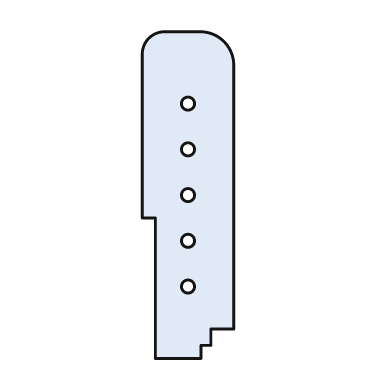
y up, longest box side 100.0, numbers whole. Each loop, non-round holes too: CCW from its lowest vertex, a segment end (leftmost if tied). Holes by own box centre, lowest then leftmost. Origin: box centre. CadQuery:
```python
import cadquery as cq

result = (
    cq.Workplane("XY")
    .moveTo(-10.0, -50.0)
    .lineTo(4.0, -50.0)
    .lineTo(4.0, -46.0)
    .lineTo(7.0, -46.0)
    .lineTo(7.0, -41.0)
    .lineTo(14.0, -41.0)
    .lineTo(14.0, 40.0)
    .threePointArc((11.0, 47.0), (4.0, 50.0))
    .lineTo(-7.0, 50.0)
    .threePointArc((-12.0, 48.0), (-14.0, 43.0))
    .lineTo(-14.0, -7.0)
    .lineTo(-10.0, -7.0)
    .close()
    .moveTo(0.0, -28.0)
    .circle(2.0)
    .moveTo(0.0, -14.0)
    .circle(2.0)
    .moveTo(0.0, 0.0)
    .circle(2.0)
    .moveTo(0.0, 14.0)
    .circle(2.0)
    .moveTo(0.0, 28.0)
    .circle(2.0)
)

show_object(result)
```